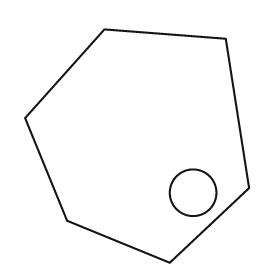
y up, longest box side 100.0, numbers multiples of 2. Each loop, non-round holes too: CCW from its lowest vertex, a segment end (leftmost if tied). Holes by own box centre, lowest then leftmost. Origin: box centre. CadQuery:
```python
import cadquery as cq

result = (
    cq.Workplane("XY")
    .moveTo(14.0, -50.0)
    .lineTo(48.0, -18.0)
    .lineTo(38.0, 46.0)
    .lineTo(-14.0, 50.0)
    .lineTo(-48.0, 12.0)
    .lineTo(-30.0, -32.0)
    .close()
    .moveTo(24.0, -20.0)
    .circle(10.0)
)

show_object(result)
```